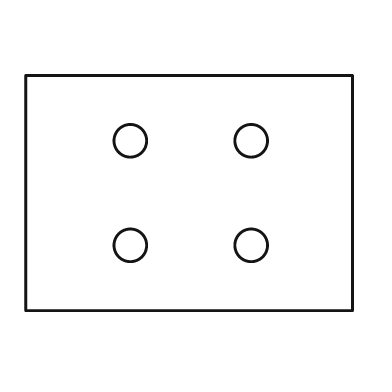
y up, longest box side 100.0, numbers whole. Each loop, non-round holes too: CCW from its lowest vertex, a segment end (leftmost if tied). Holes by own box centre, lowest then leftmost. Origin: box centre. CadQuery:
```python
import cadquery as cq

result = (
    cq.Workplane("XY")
    .moveTo(-50.0, -36.0)
    .lineTo(50.0, -36.0)
    .lineTo(50.0, 36.0)
    .lineTo(-50.0, 36.0)
    .close()
    .moveTo(-18.0, -16.0)
    .circle(5.0)
    .moveTo(19.0, -16.0)
    .circle(5.0)
    .moveTo(-18.0, 16.0)
    .circle(5.0)
    .moveTo(19.0, 16.0)
    .circle(5.0)
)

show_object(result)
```